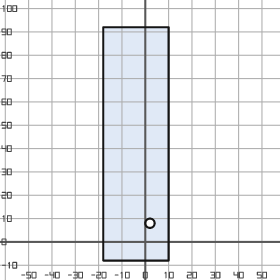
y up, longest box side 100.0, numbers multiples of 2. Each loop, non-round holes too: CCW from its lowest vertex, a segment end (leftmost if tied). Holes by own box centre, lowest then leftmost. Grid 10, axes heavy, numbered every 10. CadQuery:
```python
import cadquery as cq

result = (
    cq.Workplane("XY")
    .moveTo(-18.0, -8.0)
    .lineTo(10.0, -8.0)
    .lineTo(10.0, 92.0)
    .lineTo(-18.0, 92.0)
    .close()
    .moveTo(2.0, 8.0)
    .circle(2.0)
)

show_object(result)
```